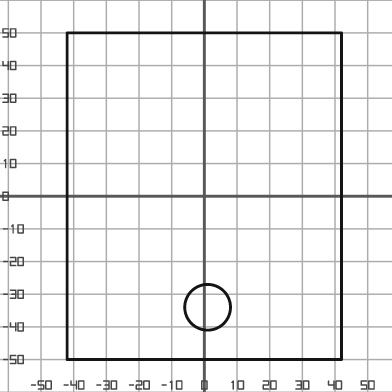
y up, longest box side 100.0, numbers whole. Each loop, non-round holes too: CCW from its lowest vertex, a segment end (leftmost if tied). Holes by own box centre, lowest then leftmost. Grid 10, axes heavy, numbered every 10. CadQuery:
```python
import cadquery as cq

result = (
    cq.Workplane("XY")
    .moveTo(-42.0, -50.0)
    .lineTo(42.0, -50.0)
    .lineTo(42.0, 50.0)
    .lineTo(-42.0, 50.0)
    .close()
    .moveTo(1.0, -34.0)
    .circle(7.0)
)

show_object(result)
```